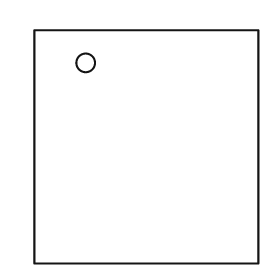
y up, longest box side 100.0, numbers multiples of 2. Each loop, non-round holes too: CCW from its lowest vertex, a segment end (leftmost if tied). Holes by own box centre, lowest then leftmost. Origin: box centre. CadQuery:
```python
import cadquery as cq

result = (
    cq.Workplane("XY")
    .moveTo(-48.0, -50.0)
    .lineTo(48.0, -50.0)
    .lineTo(48.0, 50.0)
    .lineTo(-48.0, 50.0)
    .close()
    .moveTo(-26.0, 36.0)
    .circle(4.0)
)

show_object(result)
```